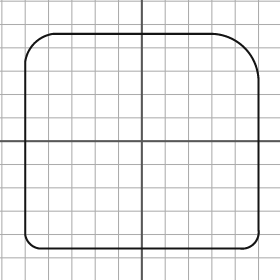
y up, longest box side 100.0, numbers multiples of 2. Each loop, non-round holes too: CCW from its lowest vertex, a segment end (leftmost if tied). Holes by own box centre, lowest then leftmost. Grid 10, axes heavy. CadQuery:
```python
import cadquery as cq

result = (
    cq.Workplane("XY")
    .moveTo(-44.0, -46.0)
    .lineTo(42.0, -46.0)
    .threePointArc((48.0, -44.0), (50.0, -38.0))
    .lineTo(50.0, 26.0)
    .threePointArc((44.0, 40.0), (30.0, 46.0))
    .lineTo(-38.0, 46.0)
    .threePointArc((-46.0, 42.0), (-50.0, 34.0))
    .lineTo(-50.0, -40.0)
    .threePointArc((-48.0, -44.0), (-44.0, -46.0))
    .close()
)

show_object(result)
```